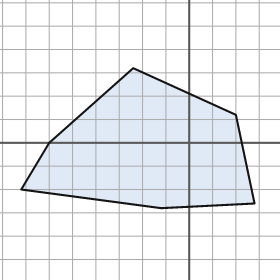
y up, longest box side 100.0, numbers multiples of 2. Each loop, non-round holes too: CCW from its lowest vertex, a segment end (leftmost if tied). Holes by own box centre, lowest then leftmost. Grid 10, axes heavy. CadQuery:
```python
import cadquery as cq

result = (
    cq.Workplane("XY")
    .moveTo(-12.0, -28.0)
    .lineTo(28.0, -26.0)
    .lineTo(20.0, 12.0)
    .lineTo(-24.0, 32.0)
    .lineTo(-60.0, 0.0)
    .lineTo(-72.0, -20.0)
    .close()
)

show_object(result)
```